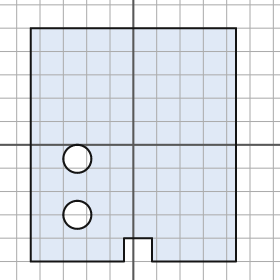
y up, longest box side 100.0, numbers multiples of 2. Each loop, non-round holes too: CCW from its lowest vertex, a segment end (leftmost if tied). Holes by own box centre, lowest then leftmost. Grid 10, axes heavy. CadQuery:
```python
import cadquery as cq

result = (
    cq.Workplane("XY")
    .moveTo(-44.0, -50.0)
    .lineTo(-4.0, -50.0)
    .lineTo(-4.0, -40.0)
    .lineTo(8.0, -40.0)
    .lineTo(8.0, -50.0)
    .lineTo(44.0, -50.0)
    .lineTo(44.0, 50.0)
    .lineTo(-44.0, 50.0)
    .close()
    .moveTo(-24.0, -30.0)
    .circle(6.0)
    .moveTo(-24.0, -6.0)
    .circle(6.0)
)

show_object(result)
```